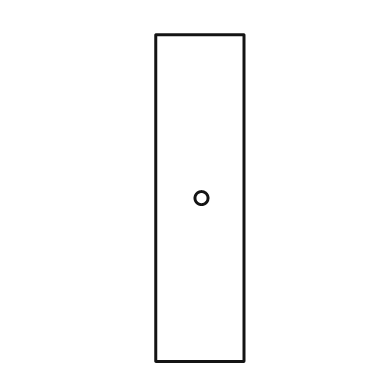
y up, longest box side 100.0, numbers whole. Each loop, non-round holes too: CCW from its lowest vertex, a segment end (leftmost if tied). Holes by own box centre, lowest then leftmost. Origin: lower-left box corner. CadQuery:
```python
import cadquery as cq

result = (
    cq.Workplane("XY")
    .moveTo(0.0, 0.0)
    .lineTo(27.0, 0.0)
    .lineTo(27.0, 100.0)
    .lineTo(0.0, 100.0)
    .close()
    .moveTo(14.0, 50.0)
    .circle(2.0)
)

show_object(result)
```